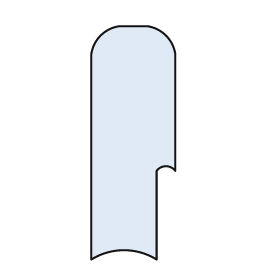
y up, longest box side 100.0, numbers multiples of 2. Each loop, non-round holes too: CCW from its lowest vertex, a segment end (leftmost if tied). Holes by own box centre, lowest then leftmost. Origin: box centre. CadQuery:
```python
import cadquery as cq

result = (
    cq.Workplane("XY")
    .moveTo(-18.0, -50.0)
    .threePointArc((-4.0, -46.0), (10.0, -50.0))
    .lineTo(10.0, -12.0)
    .threePointArc((14.0, -10.0), (18.0, -12.0))
    .lineTo(18.0, 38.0)
    .threePointArc((14.0, 46.0), (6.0, 50.0))
    .lineTo(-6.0, 50.0)
    .threePointArc((-14.0, 46.0), (-18.0, 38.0))
    .close()
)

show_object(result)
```